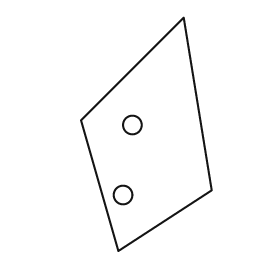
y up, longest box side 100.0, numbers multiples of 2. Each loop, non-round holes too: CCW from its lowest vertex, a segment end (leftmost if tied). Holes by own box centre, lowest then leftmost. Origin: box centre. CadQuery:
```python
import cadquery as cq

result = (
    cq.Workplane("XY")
    .moveTo(-12.0, -50.0)
    .lineTo(28.0, -24.0)
    .lineTo(16.0, 50.0)
    .lineTo(-28.0, 6.0)
    .close()
    .moveTo(-10.0, -26.0)
    .circle(4.0)
    .moveTo(-6.0, 4.0)
    .circle(4.0)
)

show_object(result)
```